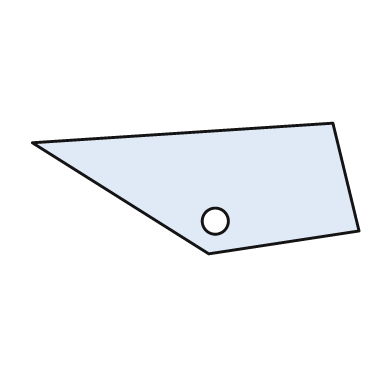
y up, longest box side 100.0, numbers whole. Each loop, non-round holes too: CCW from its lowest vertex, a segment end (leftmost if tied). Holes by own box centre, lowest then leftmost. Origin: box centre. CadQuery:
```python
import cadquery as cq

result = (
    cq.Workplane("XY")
    .moveTo(4.0, -20.0)
    .lineTo(50.0, -13.0)
    .lineTo(42.0, 20.0)
    .lineTo(-50.0, 14.0)
    .close()
    .moveTo(6.0, -10.0)
    .circle(4.0)
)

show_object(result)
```